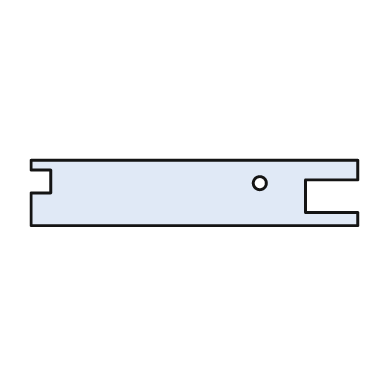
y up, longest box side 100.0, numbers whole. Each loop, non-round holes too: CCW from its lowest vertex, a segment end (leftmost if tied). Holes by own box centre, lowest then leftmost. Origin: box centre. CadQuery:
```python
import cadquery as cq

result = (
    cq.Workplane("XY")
    .moveTo(-50.0, -10.0)
    .lineTo(50.0, -10.0)
    .lineTo(50.0, -6.0)
    .lineTo(34.0, -6.0)
    .lineTo(34.0, 4.0)
    .lineTo(50.0, 4.0)
    .lineTo(50.0, 10.0)
    .lineTo(-50.0, 10.0)
    .lineTo(-50.0, 7.0)
    .lineTo(-44.0, 7.0)
    .lineTo(-44.0, 0.0)
    .lineTo(-50.0, 0.0)
    .close()
    .moveTo(20.0, 3.0)
    .circle(2.0)
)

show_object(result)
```